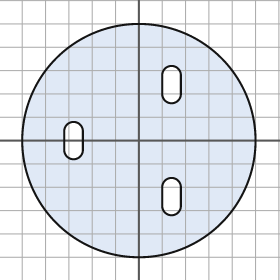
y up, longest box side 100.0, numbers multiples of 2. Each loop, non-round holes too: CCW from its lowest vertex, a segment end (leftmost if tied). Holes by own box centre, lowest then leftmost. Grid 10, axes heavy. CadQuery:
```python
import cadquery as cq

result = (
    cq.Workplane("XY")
    .moveTo(0.0, 0.0)
    .circle(50.0)
    .moveTo(10.0, -28.0)
    .threePointArc((14.0, -32.0), (18.0, -28.0))
    .lineTo(18.0, -20.0)
    .threePointArc((14.0, -16.0), (10.0, -20.0))
    .close()
    .moveTo(-32.0, -4.0)
    .threePointArc((-28.0, -8.0), (-24.0, -4.0))
    .lineTo(-24.0, 4.0)
    .threePointArc((-28.0, 8.0), (-32.0, 4.0))
    .close()
    .moveTo(10.0, 20.0)
    .threePointArc((14.0, 16.0), (18.0, 20.0))
    .lineTo(18.0, 28.0)
    .threePointArc((14.0, 32.0), (10.0, 28.0))
    .close()
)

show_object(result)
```